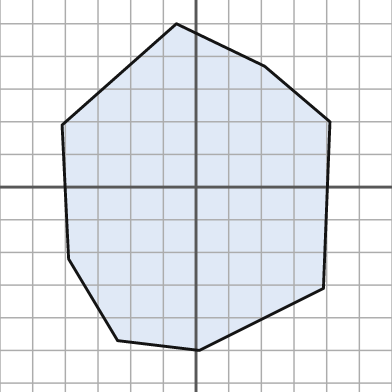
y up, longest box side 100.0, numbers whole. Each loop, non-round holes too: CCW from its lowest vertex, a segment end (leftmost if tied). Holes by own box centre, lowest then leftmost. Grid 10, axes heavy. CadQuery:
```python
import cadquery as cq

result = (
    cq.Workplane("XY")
    .moveTo(1.0, -50.0)
    .lineTo(39.0, -31.0)
    .lineTo(41.0, 20.0)
    .lineTo(21.0, 37.0)
    .lineTo(-6.0, 50.0)
    .lineTo(-41.0, 19.0)
    .lineTo(-39.0, -22.0)
    .lineTo(-24.0, -47.0)
    .close()
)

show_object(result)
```